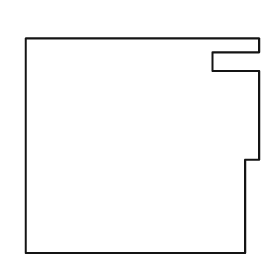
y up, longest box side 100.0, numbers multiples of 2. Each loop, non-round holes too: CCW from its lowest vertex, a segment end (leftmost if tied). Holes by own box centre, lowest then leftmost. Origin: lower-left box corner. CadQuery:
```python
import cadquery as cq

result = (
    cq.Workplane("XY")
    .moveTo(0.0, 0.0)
    .lineTo(94.0, 0.0)
    .lineTo(94.0, 40.0)
    .lineTo(100.0, 40.0)
    .lineTo(100.0, 78.0)
    .lineTo(80.0, 78.0)
    .lineTo(80.0, 86.0)
    .lineTo(100.0, 86.0)
    .lineTo(100.0, 92.0)
    .lineTo(0.0, 92.0)
    .close()
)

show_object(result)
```